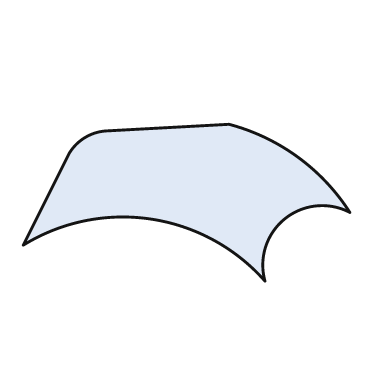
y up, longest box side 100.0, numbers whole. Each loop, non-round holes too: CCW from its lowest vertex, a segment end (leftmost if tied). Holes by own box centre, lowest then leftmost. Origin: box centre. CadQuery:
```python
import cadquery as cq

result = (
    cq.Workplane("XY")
    .moveTo(24.0, -24.0)
    .threePointArc((30.0, -5.0), (50.0, -3.0))
    .threePointArc((34.0, 14.0), (13.0, 24.0))
    .lineTo(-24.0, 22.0)
    .threePointArc((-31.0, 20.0), (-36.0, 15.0))
    .lineTo(-50.0, -13.0)
    .threePointArc((-11.0, -5.0), (24.0, -24.0))
    .close()
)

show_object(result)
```